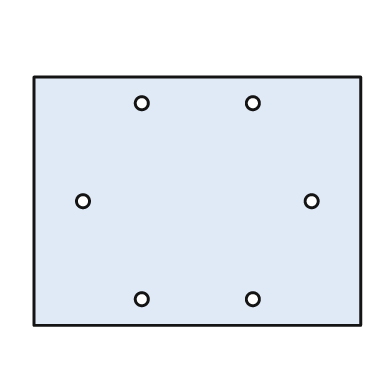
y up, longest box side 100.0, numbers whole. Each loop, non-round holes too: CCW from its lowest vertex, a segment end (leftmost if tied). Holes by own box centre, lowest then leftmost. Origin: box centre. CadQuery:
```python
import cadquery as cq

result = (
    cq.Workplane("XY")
    .moveTo(-50.0, -38.0)
    .lineTo(50.0, -38.0)
    .lineTo(50.0, 38.0)
    .lineTo(-50.0, 38.0)
    .close()
    .moveTo(-17.0, -30.0)
    .circle(2.0)
    .moveTo(17.0, -30.0)
    .circle(2.0)
    .moveTo(-35.0, 0.0)
    .circle(2.0)
    .moveTo(35.0, 0.0)
    .circle(2.0)
    .moveTo(-17.0, 30.0)
    .circle(2.0)
    .moveTo(17.0, 30.0)
    .circle(2.0)
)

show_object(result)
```